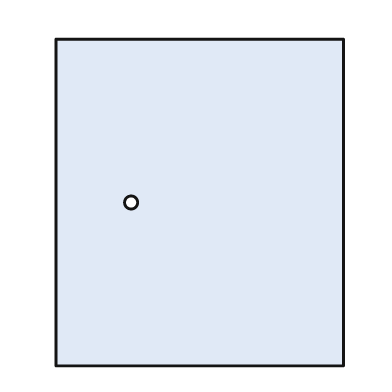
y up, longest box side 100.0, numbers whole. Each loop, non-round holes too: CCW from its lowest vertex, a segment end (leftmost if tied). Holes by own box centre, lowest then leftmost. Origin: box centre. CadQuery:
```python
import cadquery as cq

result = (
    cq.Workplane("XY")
    .moveTo(-44.0, -50.0)
    .lineTo(44.0, -50.0)
    .lineTo(44.0, 50.0)
    .lineTo(-44.0, 50.0)
    .close()
    .moveTo(-21.0, 0.0)
    .circle(2.0)
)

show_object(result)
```